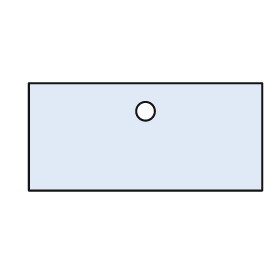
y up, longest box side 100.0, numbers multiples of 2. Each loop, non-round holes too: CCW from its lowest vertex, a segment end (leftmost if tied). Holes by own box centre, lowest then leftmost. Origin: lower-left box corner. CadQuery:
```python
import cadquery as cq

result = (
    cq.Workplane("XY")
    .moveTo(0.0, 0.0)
    .lineTo(100.0, 0.0)
    .lineTo(100.0, 46.0)
    .lineTo(0.0, 46.0)
    .close()
    .moveTo(50.0, 34.0)
    .circle(4.0)
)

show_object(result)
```